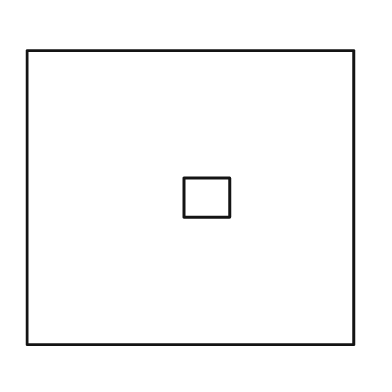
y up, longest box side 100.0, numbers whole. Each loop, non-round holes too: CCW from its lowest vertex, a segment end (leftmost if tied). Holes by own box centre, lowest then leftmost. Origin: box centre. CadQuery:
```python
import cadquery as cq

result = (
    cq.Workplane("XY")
    .moveTo(-50.0, -45.0)
    .lineTo(50.0, -45.0)
    .lineTo(50.0, 45.0)
    .lineTo(-50.0, 45.0)
    .close()
    .moveTo(-2.0, -6.0)
    .lineTo(12.0, -6.0)
    .lineTo(12.0, 6.0)
    .lineTo(-2.0, 6.0)
    .close()
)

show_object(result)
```